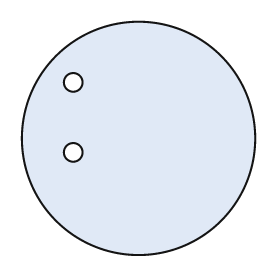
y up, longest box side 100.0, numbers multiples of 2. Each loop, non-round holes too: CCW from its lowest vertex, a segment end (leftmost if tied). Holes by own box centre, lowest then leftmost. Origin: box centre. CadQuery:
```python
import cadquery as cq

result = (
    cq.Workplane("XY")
    .moveTo(0.0, 0.0)
    .circle(50.0)
    .moveTo(-28.0, -6.0)
    .circle(4.0)
    .moveTo(-28.0, 24.0)
    .circle(4.0)
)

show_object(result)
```